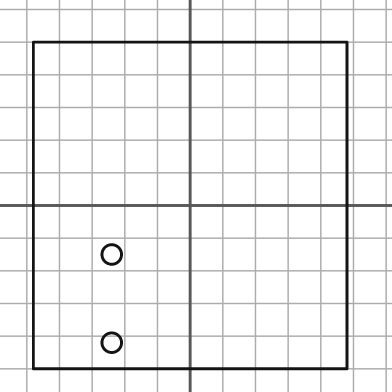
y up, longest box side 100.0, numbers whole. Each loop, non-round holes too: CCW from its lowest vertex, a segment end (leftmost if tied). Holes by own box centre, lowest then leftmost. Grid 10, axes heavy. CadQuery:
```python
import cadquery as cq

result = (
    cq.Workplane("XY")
    .moveTo(-48.0, -50.0)
    .lineTo(48.0, -50.0)
    .lineTo(48.0, 50.0)
    .lineTo(-48.0, 50.0)
    .close()
    .moveTo(-24.0, -42.0)
    .circle(3.0)
    .moveTo(-24.0, -15.0)
    .circle(3.0)
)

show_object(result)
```